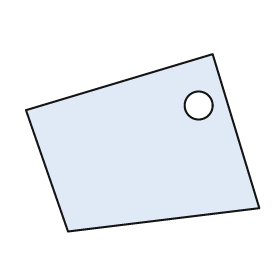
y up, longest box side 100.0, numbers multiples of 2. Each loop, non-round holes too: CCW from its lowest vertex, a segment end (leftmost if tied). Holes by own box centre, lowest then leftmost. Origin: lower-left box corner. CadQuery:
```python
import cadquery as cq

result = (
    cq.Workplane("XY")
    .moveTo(18.0, 0.0)
    .lineTo(100.0, 10.0)
    .lineTo(80.0, 76.0)
    .lineTo(0.0, 52.0)
    .close()
    .moveTo(74.0, 54.0)
    .circle(6.0)
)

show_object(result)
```